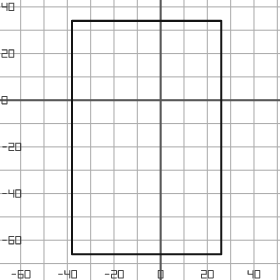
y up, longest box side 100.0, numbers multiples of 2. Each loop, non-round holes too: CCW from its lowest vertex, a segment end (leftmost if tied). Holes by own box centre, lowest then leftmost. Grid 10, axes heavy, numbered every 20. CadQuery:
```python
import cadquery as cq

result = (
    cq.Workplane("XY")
    .moveTo(-38.0, -66.0)
    .lineTo(26.0, -66.0)
    .lineTo(26.0, 34.0)
    .lineTo(-38.0, 34.0)
    .close()
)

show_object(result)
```